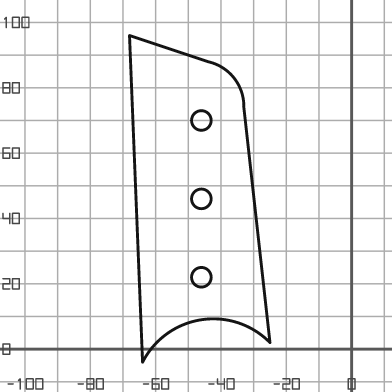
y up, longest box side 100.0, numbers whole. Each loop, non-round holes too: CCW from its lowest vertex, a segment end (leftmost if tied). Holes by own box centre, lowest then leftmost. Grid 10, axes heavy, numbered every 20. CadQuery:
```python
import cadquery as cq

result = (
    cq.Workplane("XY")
    .moveTo(-64.0, -4.0)
    .threePointArc((-46.0, 9.0), (-25.0, 2.0))
    .lineTo(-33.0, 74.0)
    .threePointArc((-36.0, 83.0), (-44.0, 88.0))
    .lineTo(-68.0, 96.0)
    .close()
    .moveTo(-46.0, 22.0)
    .circle(3.0)
    .moveTo(-46.0, 46.0)
    .circle(3.0)
    .moveTo(-46.0, 70.0)
    .circle(3.0)
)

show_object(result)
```